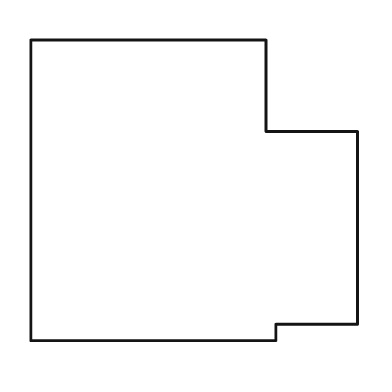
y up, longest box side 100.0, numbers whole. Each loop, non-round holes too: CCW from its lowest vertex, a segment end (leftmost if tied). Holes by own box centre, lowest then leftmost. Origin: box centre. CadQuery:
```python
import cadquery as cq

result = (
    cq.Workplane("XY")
    .moveTo(-50.0, -46.0)
    .lineTo(25.0, -46.0)
    .lineTo(25.0, -41.0)
    .lineTo(50.0, -41.0)
    .lineTo(50.0, 18.0)
    .lineTo(22.0, 18.0)
    .lineTo(22.0, 46.0)
    .lineTo(-50.0, 46.0)
    .close()
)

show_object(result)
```